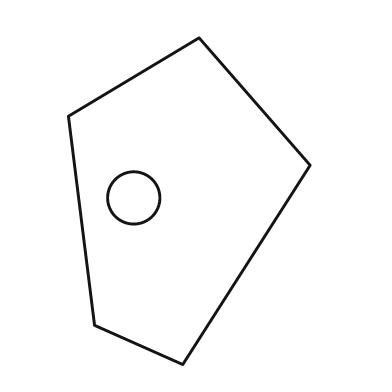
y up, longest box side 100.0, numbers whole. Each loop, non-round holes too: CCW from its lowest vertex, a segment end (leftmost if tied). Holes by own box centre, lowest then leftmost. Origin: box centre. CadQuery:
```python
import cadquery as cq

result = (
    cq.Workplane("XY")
    .moveTo(-2.0, -50.0)
    .lineTo(37.0, 11.0)
    .lineTo(3.0, 50.0)
    .lineTo(-37.0, 26.0)
    .lineTo(-29.0, -38.0)
    .close()
    .moveTo(-17.0, 1.0)
    .circle(8.0)
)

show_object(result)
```